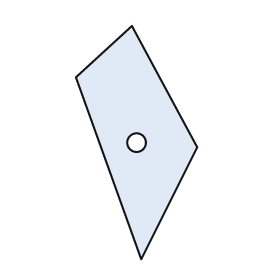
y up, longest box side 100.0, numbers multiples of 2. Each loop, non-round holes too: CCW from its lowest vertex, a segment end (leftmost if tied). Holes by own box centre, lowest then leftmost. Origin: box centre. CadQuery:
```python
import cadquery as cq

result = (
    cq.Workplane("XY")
    .moveTo(2.0, -50.0)
    .lineTo(26.0, -2.0)
    .lineTo(-2.0, 50.0)
    .lineTo(-26.0, 28.0)
    .close()
    .moveTo(0.0, 0.0)
    .circle(4.0)
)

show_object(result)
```